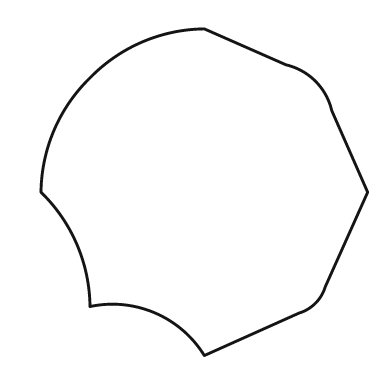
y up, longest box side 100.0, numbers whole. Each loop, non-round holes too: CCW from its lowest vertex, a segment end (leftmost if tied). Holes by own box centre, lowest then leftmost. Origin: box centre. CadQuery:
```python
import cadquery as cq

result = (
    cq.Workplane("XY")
    .moveTo(0.0, -50.0)
    .lineTo(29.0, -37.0)
    .threePointArc((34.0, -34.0), (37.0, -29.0))
    .lineTo(50.0, 0.0)
    .lineTo(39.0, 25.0)
    .threePointArc((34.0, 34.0), (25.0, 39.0))
    .lineTo(0.0, 50.0)
    .threePointArc((-19.0, 46.0), (-35.0, 35.0))
    .threePointArc((-46.0, 19.0), (-50.0, 0.0))
    .threePointArc((-39.0, -16.0), (-35.0, -35.0))
    .threePointArc((-15.0, -37.0), (0.0, -50.0))
    .close()
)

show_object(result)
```